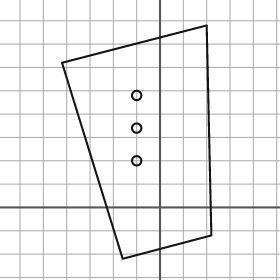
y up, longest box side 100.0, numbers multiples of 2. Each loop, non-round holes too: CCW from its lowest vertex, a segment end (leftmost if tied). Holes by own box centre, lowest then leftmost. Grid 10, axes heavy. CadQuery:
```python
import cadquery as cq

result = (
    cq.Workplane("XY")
    .moveTo(-16.0, -22.0)
    .lineTo(22.0, -12.0)
    .lineTo(20.0, 78.0)
    .lineTo(-42.0, 62.0)
    .close()
    .moveTo(-10.0, 20.0)
    .circle(2.0)
    .moveTo(-10.0, 34.0)
    .circle(2.0)
    .moveTo(-10.0, 48.0)
    .circle(2.0)
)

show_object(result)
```